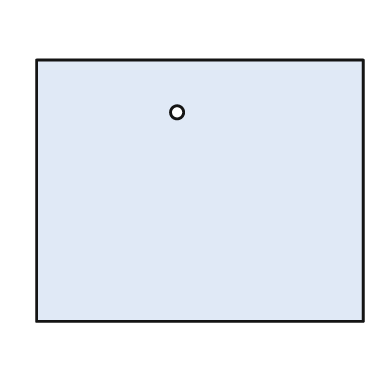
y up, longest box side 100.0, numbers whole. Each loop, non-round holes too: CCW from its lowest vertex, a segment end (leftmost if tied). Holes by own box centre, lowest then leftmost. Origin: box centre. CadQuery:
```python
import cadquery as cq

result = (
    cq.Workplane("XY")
    .moveTo(-50.0, -40.0)
    .lineTo(50.0, -40.0)
    .lineTo(50.0, 40.0)
    .lineTo(-50.0, 40.0)
    .close()
    .moveTo(-7.0, 24.0)
    .circle(2.0)
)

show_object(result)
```